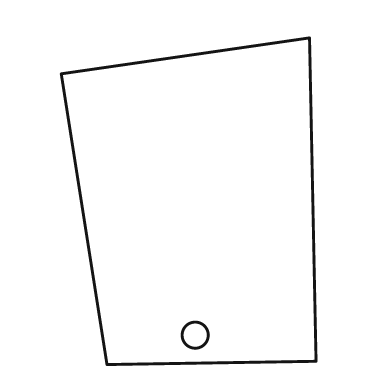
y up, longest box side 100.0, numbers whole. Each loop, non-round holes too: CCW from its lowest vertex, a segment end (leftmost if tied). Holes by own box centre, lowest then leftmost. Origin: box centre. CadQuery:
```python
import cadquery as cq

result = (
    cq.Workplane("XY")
    .moveTo(-25.0, -50.0)
    .lineTo(39.0, -49.0)
    .lineTo(37.0, 50.0)
    .lineTo(-39.0, 39.0)
    .close()
    .moveTo(2.0, -41.0)
    .circle(4.0)
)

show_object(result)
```